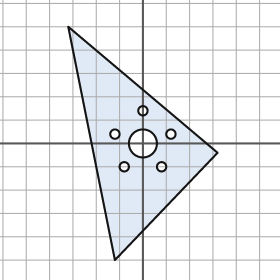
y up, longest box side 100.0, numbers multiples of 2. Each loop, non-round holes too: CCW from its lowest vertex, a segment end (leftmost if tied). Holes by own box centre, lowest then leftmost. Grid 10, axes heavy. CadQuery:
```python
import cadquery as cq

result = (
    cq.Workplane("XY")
    .moveTo(-12.0, -50.0)
    .lineTo(32.0, -4.0)
    .lineTo(-32.0, 50.0)
    .close()
    .moveTo(-8.0, -10.0)
    .circle(2.0)
    .moveTo(8.0, -10.0)
    .circle(2.0)
    .moveTo(0.0, 0.0)
    .circle(6.0)
    .moveTo(-12.0, 4.0)
    .circle(2.0)
    .moveTo(12.0, 4.0)
    .circle(2.0)
    .moveTo(0.0, 14.0)
    .circle(2.0)
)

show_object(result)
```